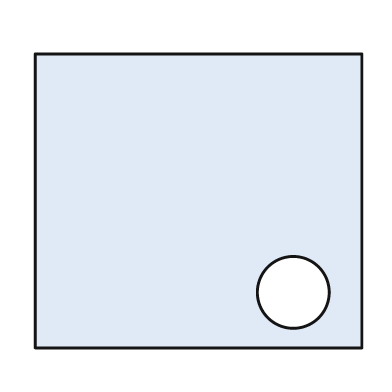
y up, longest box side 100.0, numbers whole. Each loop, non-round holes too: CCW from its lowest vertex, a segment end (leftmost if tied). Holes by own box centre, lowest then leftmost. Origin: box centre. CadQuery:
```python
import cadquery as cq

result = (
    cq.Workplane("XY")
    .moveTo(-50.0, -45.0)
    .lineTo(50.0, -45.0)
    .lineTo(50.0, 45.0)
    .lineTo(-50.0, 45.0)
    .close()
    .moveTo(29.0, -28.0)
    .circle(11.0)
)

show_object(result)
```